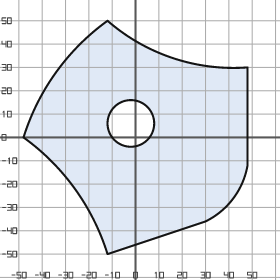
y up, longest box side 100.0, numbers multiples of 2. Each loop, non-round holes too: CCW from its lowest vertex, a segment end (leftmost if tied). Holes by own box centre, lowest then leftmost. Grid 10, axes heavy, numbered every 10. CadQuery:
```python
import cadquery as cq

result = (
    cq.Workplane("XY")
    .moveTo(-12.0, -50.0)
    .lineTo(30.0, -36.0)
    .threePointArc((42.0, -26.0), (48.0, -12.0))
    .lineTo(48.0, 30.0)
    .threePointArc((16.0, 34.0), (-12.0, 50.0))
    .threePointArc((-34.0, 28.0), (-48.0, 0.0))
    .threePointArc((-26.0, -22.0), (-12.0, -50.0))
    .close()
    .moveTo(-2.0, 6.0)
    .circle(10.0)
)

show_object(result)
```